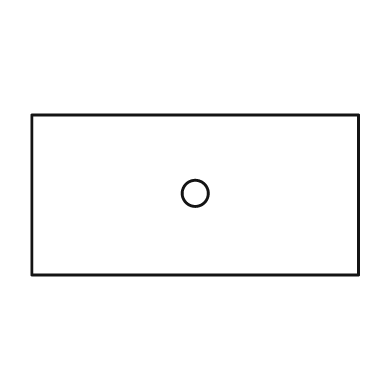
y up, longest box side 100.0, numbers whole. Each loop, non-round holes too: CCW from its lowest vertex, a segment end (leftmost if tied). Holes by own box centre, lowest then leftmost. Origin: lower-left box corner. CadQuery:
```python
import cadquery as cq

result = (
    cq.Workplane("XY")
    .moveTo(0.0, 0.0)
    .lineTo(100.0, 0.0)
    .lineTo(100.0, 49.0)
    .lineTo(0.0, 49.0)
    .close()
    .moveTo(50.0, 25.0)
    .circle(4.0)
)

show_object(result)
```